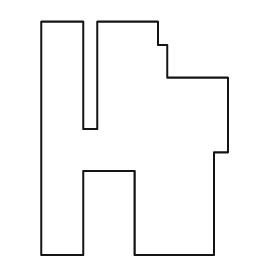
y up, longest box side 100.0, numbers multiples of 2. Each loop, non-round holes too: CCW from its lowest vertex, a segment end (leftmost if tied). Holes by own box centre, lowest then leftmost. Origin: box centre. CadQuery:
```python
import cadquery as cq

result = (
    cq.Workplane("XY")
    .moveTo(-40.0, -50.0)
    .lineTo(-22.0, -50.0)
    .lineTo(-22.0, -14.0)
    .lineTo(0.0, -14.0)
    .lineTo(0.0, -50.0)
    .lineTo(34.0, -50.0)
    .lineTo(34.0, -6.0)
    .lineTo(40.0, -6.0)
    .lineTo(40.0, 26.0)
    .lineTo(14.0, 26.0)
    .lineTo(14.0, 40.0)
    .lineTo(10.0, 40.0)
    .lineTo(10.0, 50.0)
    .lineTo(-16.0, 50.0)
    .lineTo(-16.0, 4.0)
    .lineTo(-22.0, 4.0)
    .lineTo(-22.0, 50.0)
    .lineTo(-40.0, 50.0)
    .close()
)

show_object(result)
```